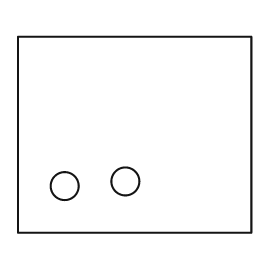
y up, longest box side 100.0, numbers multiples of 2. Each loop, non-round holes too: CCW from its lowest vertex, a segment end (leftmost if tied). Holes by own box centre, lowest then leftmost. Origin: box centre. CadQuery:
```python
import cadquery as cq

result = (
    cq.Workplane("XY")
    .moveTo(-50.0, -42.0)
    .lineTo(50.0, -42.0)
    .lineTo(50.0, 42.0)
    .lineTo(-50.0, 42.0)
    .close()
    .moveTo(-30.0, -22.0)
    .circle(6.0)
    .moveTo(-4.0, -20.0)
    .circle(6.0)
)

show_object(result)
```